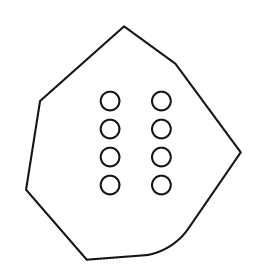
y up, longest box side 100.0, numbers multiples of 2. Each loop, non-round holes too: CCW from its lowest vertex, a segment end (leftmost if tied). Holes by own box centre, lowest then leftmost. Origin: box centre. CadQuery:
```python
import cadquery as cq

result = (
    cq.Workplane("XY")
    .moveTo(-20.0, -50.0)
    .lineTo(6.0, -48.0)
    .threePointArc((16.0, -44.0), (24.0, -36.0))
    .lineTo(46.0, -4.0)
    .lineTo(18.0, 34.0)
    .lineTo(-4.0, 50.0)
    .lineTo(-40.0, 18.0)
    .lineTo(-46.0, -20.0)
    .close()
    .moveTo(-10.0, -18.0)
    .circle(4.0)
    .moveTo(12.0, -18.0)
    .circle(4.0)
    .moveTo(-10.0, -6.0)
    .circle(4.0)
    .moveTo(12.0, -6.0)
    .circle(4.0)
    .moveTo(-10.0, 6.0)
    .circle(4.0)
    .moveTo(12.0, 6.0)
    .circle(4.0)
    .moveTo(-10.0, 18.0)
    .circle(4.0)
    .moveTo(12.0, 18.0)
    .circle(4.0)
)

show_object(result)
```